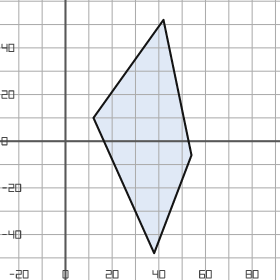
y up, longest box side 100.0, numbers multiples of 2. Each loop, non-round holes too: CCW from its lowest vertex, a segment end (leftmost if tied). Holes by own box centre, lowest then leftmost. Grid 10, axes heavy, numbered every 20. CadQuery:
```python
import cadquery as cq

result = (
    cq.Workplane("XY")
    .moveTo(38.0, -48.0)
    .lineTo(54.0, -6.0)
    .lineTo(42.0, 52.0)
    .lineTo(12.0, 10.0)
    .close()
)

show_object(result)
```